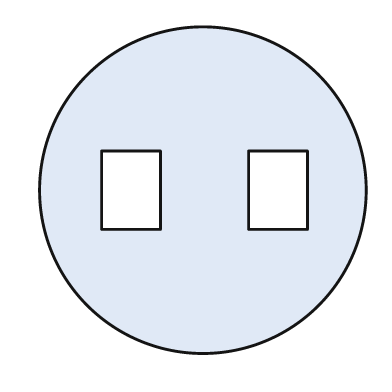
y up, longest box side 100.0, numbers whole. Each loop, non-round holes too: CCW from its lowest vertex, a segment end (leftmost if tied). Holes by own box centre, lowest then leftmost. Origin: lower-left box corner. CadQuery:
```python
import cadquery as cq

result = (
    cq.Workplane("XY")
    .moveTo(50.0, 50.0)
    .circle(50.0)
    .moveTo(19.0, 38.0)
    .lineTo(37.0, 38.0)
    .lineTo(37.0, 62.0)
    .lineTo(19.0, 62.0)
    .close()
    .moveTo(64.0, 38.0)
    .lineTo(82.0, 38.0)
    .lineTo(82.0, 62.0)
    .lineTo(64.0, 62.0)
    .close()
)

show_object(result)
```